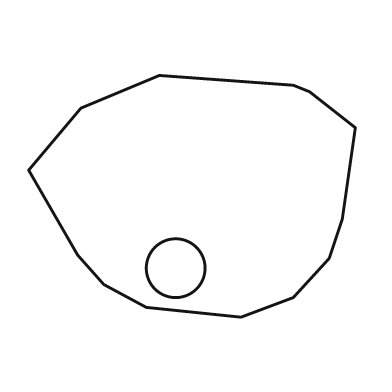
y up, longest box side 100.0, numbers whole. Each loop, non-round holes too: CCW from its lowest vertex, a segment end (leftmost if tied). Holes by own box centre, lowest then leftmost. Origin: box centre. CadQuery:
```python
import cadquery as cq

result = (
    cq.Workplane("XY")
    .moveTo(15.0, -37.0)
    .lineTo(31.0, -31.0)
    .lineTo(42.0, -19.0)
    .lineTo(46.0, -7.0)
    .lineTo(50.0, 21.0)
    .lineTo(36.0, 32.0)
    .lineTo(31.0, 34.0)
    .lineTo(-10.0, 37.0)
    .lineTo(-34.0, 27.0)
    .lineTo(-50.0, 8.0)
    .lineTo(-35.0, -18.0)
    .lineTo(-27.0, -27.0)
    .lineTo(-14.0, -34.0)
    .close()
    .moveTo(-5.0, -22.0)
    .circle(9.0)
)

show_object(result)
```